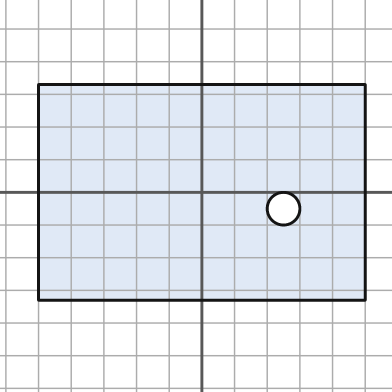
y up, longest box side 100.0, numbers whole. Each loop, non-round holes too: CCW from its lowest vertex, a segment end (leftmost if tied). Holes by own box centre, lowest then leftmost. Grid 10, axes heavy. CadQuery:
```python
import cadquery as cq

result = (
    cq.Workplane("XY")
    .moveTo(-50.0, -33.0)
    .lineTo(50.0, -33.0)
    .lineTo(50.0, 33.0)
    .lineTo(-50.0, 33.0)
    .close()
    .moveTo(25.0, -5.0)
    .circle(5.0)
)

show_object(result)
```